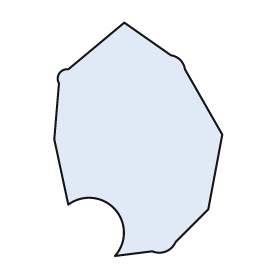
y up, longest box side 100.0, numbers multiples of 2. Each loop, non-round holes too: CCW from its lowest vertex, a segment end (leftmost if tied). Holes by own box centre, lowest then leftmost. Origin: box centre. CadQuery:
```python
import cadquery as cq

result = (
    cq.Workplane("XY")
    .moveTo(-10.0, -50.0)
    .lineTo(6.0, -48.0)
    .threePointArc((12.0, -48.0), (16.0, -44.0))
    .lineTo(30.0, -30.0)
    .lineTo(36.0, 2.0)
    .lineTo(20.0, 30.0)
    .threePointArc((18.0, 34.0), (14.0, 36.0))
    .lineTo(-6.0, 50.0)
    .lineTo(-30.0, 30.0)
    .threePointArc((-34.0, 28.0), (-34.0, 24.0))
    .lineTo(-36.0, 0.0)
    .lineTo(-30.0, -28.0)
    .threePointArc((-10.0, -30.0), (-10.0, -50.0))
    .close()
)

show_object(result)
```